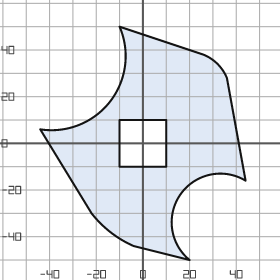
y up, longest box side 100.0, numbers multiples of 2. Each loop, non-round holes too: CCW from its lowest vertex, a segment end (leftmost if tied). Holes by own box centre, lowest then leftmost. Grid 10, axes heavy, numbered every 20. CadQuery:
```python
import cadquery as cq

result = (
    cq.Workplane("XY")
    .moveTo(20.0, -50.0)
    .threePointArc((16.0, -22.0), (44.0, -16.0))
    .lineTo(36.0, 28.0)
    .threePointArc((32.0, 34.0), (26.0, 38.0))
    .lineTo(-10.0, 50.0)
    .threePointArc((-14.0, 18.0), (-44.0, 6.0))
    .lineTo(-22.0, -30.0)
    .threePointArc((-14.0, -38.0), (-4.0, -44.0))
    .close()
    .moveTo(-10.0, -10.0)
    .lineTo(10.0, -10.0)
    .lineTo(10.0, 10.0)
    .lineTo(-10.0, 10.0)
    .close()
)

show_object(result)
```